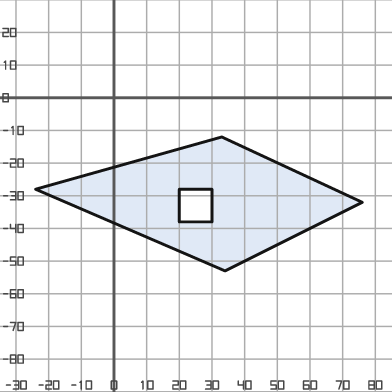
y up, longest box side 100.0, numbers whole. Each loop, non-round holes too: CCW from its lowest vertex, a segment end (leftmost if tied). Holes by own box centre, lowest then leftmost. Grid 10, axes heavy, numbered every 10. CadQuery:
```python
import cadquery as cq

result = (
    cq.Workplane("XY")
    .moveTo(34.0, -53.0)
    .lineTo(76.0, -32.0)
    .lineTo(33.0, -12.0)
    .lineTo(-24.0, -28.0)
    .close()
    .moveTo(20.0, -38.0)
    .lineTo(30.0, -38.0)
    .lineTo(30.0, -28.0)
    .lineTo(20.0, -28.0)
    .close()
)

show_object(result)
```